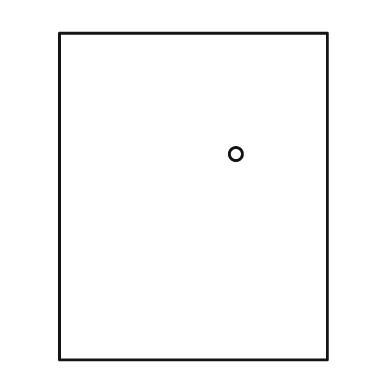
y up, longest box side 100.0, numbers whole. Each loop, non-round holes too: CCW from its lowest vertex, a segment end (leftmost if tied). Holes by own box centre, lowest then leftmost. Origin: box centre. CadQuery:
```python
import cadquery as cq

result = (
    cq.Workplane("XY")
    .moveTo(-41.0, -50.0)
    .lineTo(41.0, -50.0)
    .lineTo(41.0, 50.0)
    .lineTo(-41.0, 50.0)
    .close()
    .moveTo(13.0, 13.0)
    .circle(2.0)
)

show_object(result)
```